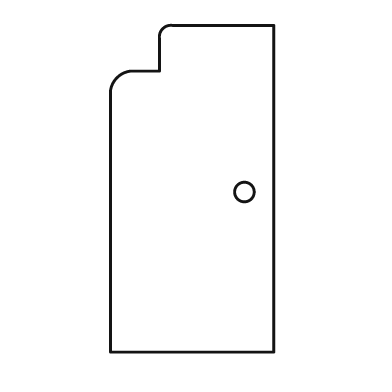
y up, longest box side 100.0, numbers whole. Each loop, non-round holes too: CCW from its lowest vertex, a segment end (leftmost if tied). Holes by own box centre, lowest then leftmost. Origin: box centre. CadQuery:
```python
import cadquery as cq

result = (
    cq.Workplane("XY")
    .moveTo(-25.0, -50.0)
    .lineTo(25.0, -50.0)
    .lineTo(25.0, 50.0)
    .lineTo(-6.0, 50.0)
    .threePointArc((-9.0, 49.0), (-10.0, 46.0))
    .lineTo(-10.0, 36.0)
    .lineTo(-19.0, 36.0)
    .threePointArc((-23.0, 34.0), (-25.0, 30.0))
    .close()
    .moveTo(16.0, -1.0)
    .circle(3.0)
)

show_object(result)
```